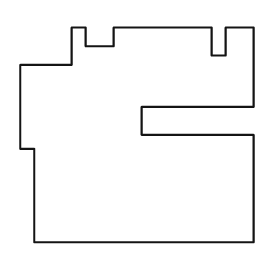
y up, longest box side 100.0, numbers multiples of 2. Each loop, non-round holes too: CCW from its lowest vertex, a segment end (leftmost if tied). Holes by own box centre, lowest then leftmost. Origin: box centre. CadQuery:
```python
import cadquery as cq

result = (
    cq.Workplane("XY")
    .moveTo(-44.0, -46.0)
    .lineTo(50.0, -46.0)
    .lineTo(50.0, 0.0)
    .lineTo(2.0, 0.0)
    .lineTo(2.0, 12.0)
    .lineTo(50.0, 12.0)
    .lineTo(50.0, 46.0)
    .lineTo(38.0, 46.0)
    .lineTo(38.0, 34.0)
    .lineTo(32.0, 34.0)
    .lineTo(32.0, 46.0)
    .lineTo(-10.0, 46.0)
    .lineTo(-10.0, 38.0)
    .lineTo(-22.0, 38.0)
    .lineTo(-22.0, 46.0)
    .lineTo(-28.0, 46.0)
    .lineTo(-28.0, 30.0)
    .lineTo(-50.0, 30.0)
    .lineTo(-50.0, -6.0)
    .lineTo(-44.0, -6.0)
    .close()
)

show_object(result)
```